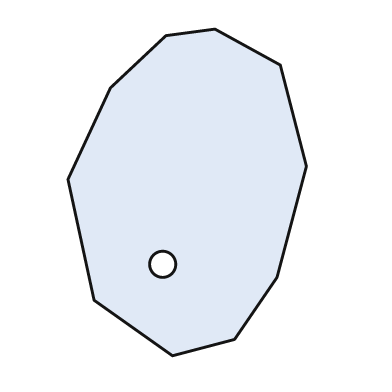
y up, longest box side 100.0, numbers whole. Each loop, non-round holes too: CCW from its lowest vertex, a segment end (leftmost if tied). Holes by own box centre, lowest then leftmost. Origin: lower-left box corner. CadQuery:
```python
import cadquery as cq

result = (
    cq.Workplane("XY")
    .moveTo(32.0, 0.0)
    .lineTo(51.0, 5.0)
    .lineTo(64.0, 24.0)
    .lineTo(73.0, 58.0)
    .lineTo(65.0, 89.0)
    .lineTo(45.0, 100.0)
    .lineTo(30.0, 98.0)
    .lineTo(13.0, 82.0)
    .lineTo(0.0, 54.0)
    .lineTo(8.0, 17.0)
    .close()
    .moveTo(29.0, 28.0)
    .circle(4.0)
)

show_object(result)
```